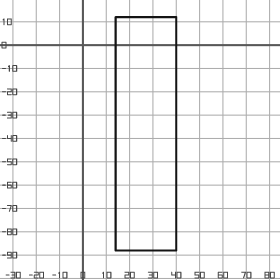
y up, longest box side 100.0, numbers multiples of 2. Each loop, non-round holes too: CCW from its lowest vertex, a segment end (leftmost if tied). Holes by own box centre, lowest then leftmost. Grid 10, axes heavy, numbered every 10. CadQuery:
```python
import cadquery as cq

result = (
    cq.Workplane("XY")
    .moveTo(14.0, -88.0)
    .lineTo(40.0, -88.0)
    .lineTo(40.0, 12.0)
    .lineTo(14.0, 12.0)
    .close()
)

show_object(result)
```